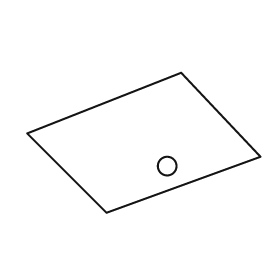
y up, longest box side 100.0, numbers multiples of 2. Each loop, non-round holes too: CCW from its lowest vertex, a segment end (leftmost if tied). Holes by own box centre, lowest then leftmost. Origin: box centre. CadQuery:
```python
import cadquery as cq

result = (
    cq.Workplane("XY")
    .moveTo(-16.0, -30.0)
    .lineTo(50.0, -6.0)
    .lineTo(16.0, 30.0)
    .lineTo(-50.0, 4.0)
    .close()
    .moveTo(10.0, -10.0)
    .circle(4.0)
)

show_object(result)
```